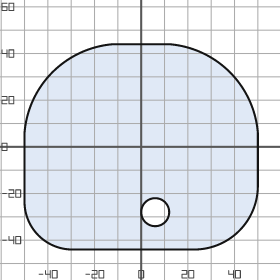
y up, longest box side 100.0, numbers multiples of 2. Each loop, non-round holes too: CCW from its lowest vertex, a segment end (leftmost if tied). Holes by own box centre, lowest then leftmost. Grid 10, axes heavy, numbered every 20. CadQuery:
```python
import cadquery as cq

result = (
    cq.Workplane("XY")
    .moveTo(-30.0, -44.0)
    .lineTo(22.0, -44.0)
    .threePointArc((42.0, -36.0), (50.0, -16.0))
    .lineTo(50.0, 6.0)
    .threePointArc((38.0, 32.0), (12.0, 44.0))
    .lineTo(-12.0, 44.0)
    .threePointArc((-38.0, 32.0), (-50.0, 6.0))
    .lineTo(-50.0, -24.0)
    .threePointArc((-44.0, -38.0), (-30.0, -44.0))
    .close()
    .moveTo(6.0, -28.0)
    .circle(6.0)
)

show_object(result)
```